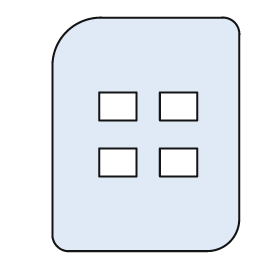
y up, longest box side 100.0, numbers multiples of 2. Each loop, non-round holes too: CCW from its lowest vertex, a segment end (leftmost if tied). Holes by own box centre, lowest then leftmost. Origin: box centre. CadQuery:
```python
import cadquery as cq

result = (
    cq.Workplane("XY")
    .moveTo(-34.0, -50.0)
    .lineTo(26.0, -50.0)
    .threePointArc((36.0, -46.0), (40.0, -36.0))
    .lineTo(40.0, 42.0)
    .threePointArc((38.0, 48.0), (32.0, 50.0))
    .lineTo(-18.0, 50.0)
    .threePointArc((-34.0, 44.0), (-40.0, 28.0))
    .lineTo(-40.0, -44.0)
    .threePointArc((-38.0, -48.0), (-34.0, -50.0))
    .close()
    .moveTo(-20.0, -18.0)
    .lineTo(-4.0, -18.0)
    .lineTo(-4.0, -6.0)
    .lineTo(-20.0, -6.0)
    .close()
    .moveTo(6.0, -18.0)
    .lineTo(22.0, -18.0)
    .lineTo(22.0, -6.0)
    .lineTo(6.0, -6.0)
    .close()
    .moveTo(-20.0, 6.0)
    .lineTo(-4.0, 6.0)
    .lineTo(-4.0, 18.0)
    .lineTo(-20.0, 18.0)
    .close()
    .moveTo(6.0, 6.0)
    .lineTo(22.0, 6.0)
    .lineTo(22.0, 18.0)
    .lineTo(6.0, 18.0)
    .close()
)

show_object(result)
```